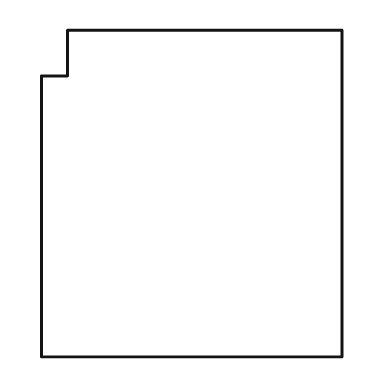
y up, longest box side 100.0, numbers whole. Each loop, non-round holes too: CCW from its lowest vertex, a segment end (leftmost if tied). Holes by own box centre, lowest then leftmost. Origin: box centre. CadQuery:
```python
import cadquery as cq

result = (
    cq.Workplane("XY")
    .moveTo(-46.0, -50.0)
    .lineTo(46.0, -50.0)
    .lineTo(46.0, 50.0)
    .lineTo(-38.0, 50.0)
    .lineTo(-38.0, 36.0)
    .lineTo(-46.0, 36.0)
    .close()
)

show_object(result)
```